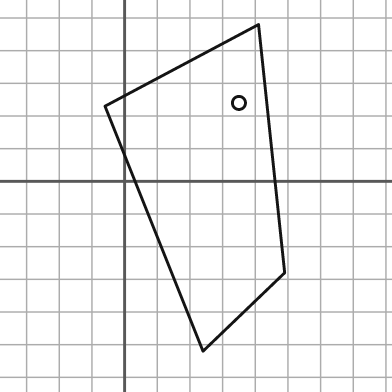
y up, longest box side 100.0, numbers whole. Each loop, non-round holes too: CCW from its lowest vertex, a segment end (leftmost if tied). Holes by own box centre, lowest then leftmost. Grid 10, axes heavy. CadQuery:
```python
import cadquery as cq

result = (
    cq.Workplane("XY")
    .moveTo(24.0, -52.0)
    .lineTo(49.0, -28.0)
    .lineTo(41.0, 48.0)
    .lineTo(-6.0, 23.0)
    .close()
    .moveTo(35.0, 24.0)
    .circle(2.0)
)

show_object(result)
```